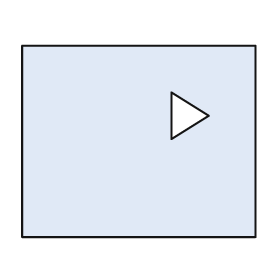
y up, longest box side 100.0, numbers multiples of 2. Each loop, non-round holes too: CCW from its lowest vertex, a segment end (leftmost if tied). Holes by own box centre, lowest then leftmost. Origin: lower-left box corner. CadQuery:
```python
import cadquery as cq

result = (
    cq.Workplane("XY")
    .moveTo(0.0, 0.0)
    .lineTo(100.0, 0.0)
    .lineTo(100.0, 82.0)
    .lineTo(0.0, 82.0)
    .close()
    .moveTo(64.0, 42.0)
    .lineTo(80.0, 52.0)
    .lineTo(64.0, 62.0)
    .close()
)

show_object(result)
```